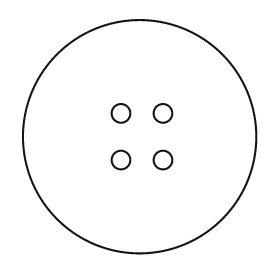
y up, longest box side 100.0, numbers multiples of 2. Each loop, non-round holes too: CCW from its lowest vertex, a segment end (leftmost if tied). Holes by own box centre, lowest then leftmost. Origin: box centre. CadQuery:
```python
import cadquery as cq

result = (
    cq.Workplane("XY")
    .moveTo(0.0, 0.0)
    .circle(50.0)
    .moveTo(-8.0, -10.0)
    .circle(4.0)
    .moveTo(10.0, -10.0)
    .circle(4.0)
    .moveTo(-8.0, 10.0)
    .circle(4.0)
    .moveTo(10.0, 10.0)
    .circle(4.0)
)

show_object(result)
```